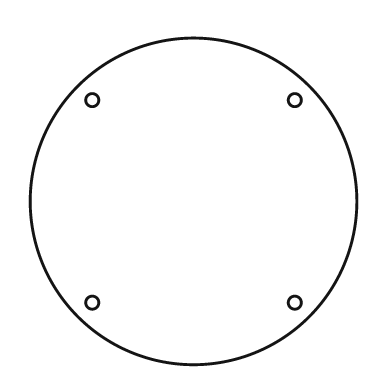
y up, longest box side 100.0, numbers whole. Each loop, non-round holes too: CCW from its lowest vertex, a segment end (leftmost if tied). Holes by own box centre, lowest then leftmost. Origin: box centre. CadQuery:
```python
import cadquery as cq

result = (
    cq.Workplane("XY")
    .moveTo(0.0, 0.0)
    .circle(50.0)
    .moveTo(-31.0, -31.0)
    .circle(2.0)
    .moveTo(31.0, -31.0)
    .circle(2.0)
    .moveTo(-31.0, 31.0)
    .circle(2.0)
    .moveTo(31.0, 31.0)
    .circle(2.0)
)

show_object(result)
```